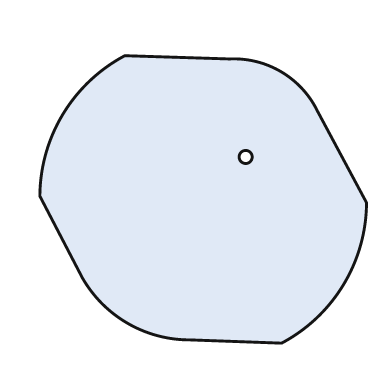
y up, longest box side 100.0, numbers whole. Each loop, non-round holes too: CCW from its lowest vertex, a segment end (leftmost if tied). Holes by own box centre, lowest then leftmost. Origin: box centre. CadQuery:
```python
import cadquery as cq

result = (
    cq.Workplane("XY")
    .moveTo(24.0, -44.0)
    .threePointArc((43.0, -26.0), (50.0, -1.0))
    .lineTo(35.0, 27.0)
    .threePointArc((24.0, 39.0), (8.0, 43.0))
    .lineTo(-24.0, 44.0)
    .threePointArc((-43.0, 26.0), (-50.0, 1.0))
    .lineTo(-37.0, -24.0)
    .threePointArc((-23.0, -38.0), (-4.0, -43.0))
    .close()
    .moveTo(13.0, 13.0)
    .circle(2.0)
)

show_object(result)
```